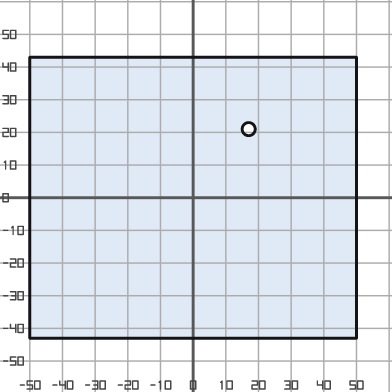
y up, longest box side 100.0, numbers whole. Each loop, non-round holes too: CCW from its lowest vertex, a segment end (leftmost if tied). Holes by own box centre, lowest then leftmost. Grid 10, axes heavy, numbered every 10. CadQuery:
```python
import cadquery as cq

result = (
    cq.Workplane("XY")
    .moveTo(-50.0, -43.0)
    .lineTo(50.0, -43.0)
    .lineTo(50.0, 43.0)
    .lineTo(-50.0, 43.0)
    .close()
    .moveTo(17.0, 21.0)
    .circle(2.0)
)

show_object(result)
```